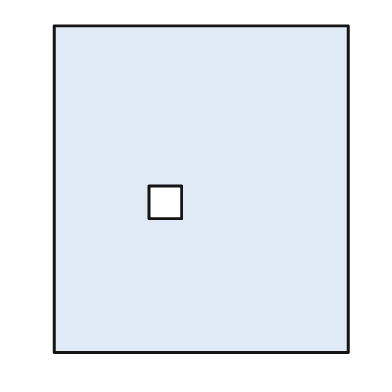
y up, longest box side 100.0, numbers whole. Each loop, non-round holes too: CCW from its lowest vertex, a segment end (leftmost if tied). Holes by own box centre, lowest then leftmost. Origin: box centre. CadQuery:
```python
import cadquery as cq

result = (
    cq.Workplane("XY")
    .moveTo(-45.0, -50.0)
    .lineTo(45.0, -50.0)
    .lineTo(45.0, 50.0)
    .lineTo(-45.0, 50.0)
    .close()
    .moveTo(-16.0, -9.0)
    .lineTo(-6.0, -9.0)
    .lineTo(-6.0, 1.0)
    .lineTo(-16.0, 1.0)
    .close()
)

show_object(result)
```